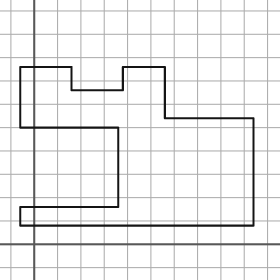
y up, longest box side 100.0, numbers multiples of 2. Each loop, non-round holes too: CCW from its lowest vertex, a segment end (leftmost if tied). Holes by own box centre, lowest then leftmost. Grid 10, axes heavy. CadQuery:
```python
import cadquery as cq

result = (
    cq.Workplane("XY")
    .moveTo(-6.0, 8.0)
    .lineTo(94.0, 8.0)
    .lineTo(94.0, 54.0)
    .lineTo(56.0, 54.0)
    .lineTo(56.0, 76.0)
    .lineTo(38.0, 76.0)
    .lineTo(38.0, 66.0)
    .lineTo(16.0, 66.0)
    .lineTo(16.0, 76.0)
    .lineTo(-6.0, 76.0)
    .lineTo(-6.0, 50.0)
    .lineTo(36.0, 50.0)
    .lineTo(36.0, 16.0)
    .lineTo(-6.0, 16.0)
    .close()
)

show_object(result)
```